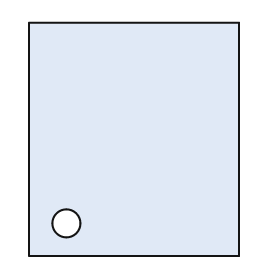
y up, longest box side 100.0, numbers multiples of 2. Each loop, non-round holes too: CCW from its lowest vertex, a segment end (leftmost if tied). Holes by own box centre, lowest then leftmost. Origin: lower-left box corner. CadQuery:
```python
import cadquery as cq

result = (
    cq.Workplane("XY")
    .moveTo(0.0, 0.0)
    .lineTo(90.0, 0.0)
    .lineTo(90.0, 100.0)
    .lineTo(0.0, 100.0)
    .close()
    .moveTo(16.0, 14.0)
    .circle(6.0)
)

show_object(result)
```